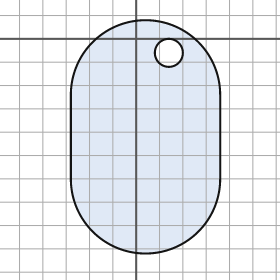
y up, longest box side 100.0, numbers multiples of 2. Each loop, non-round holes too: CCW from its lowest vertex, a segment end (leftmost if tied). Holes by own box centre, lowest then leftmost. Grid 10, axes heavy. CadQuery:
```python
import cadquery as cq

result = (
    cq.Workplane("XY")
    .moveTo(-28.0, -60.0)
    .threePointArc((4.0, -92.0), (36.0, -60.0))
    .lineTo(36.0, -24.0)
    .threePointArc((4.0, 8.0), (-28.0, -24.0))
    .close()
    .moveTo(14.0, -6.0)
    .circle(6.0)
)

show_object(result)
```